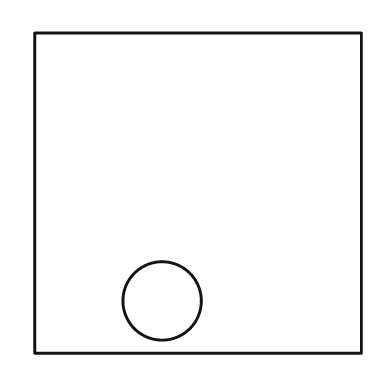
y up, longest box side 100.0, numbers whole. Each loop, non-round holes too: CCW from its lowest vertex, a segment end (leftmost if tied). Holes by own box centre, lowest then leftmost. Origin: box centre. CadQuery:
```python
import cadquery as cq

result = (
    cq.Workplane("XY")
    .moveTo(-50.0, -49.0)
    .lineTo(50.0, -49.0)
    .lineTo(50.0, 49.0)
    .lineTo(-50.0, 49.0)
    .close()
    .moveTo(-11.0, -33.0)
    .circle(12.0)
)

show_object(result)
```